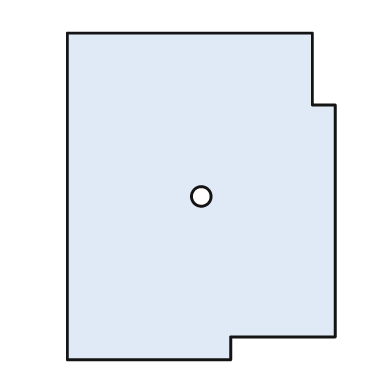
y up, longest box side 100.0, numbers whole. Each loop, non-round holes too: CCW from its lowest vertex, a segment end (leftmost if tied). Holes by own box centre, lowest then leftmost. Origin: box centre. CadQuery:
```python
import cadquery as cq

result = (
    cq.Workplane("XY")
    .moveTo(-41.0, -50.0)
    .lineTo(9.0, -50.0)
    .lineTo(9.0, -43.0)
    .lineTo(41.0, -43.0)
    .lineTo(41.0, 28.0)
    .lineTo(34.0, 28.0)
    .lineTo(34.0, 50.0)
    .lineTo(-41.0, 50.0)
    .close()
    .moveTo(0.0, 0.0)
    .circle(3.0)
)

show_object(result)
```